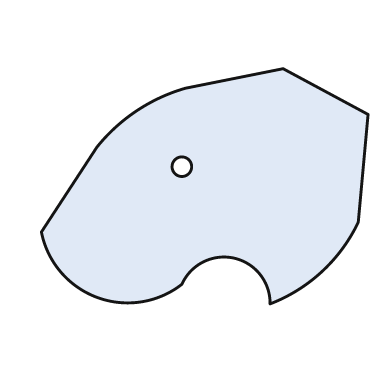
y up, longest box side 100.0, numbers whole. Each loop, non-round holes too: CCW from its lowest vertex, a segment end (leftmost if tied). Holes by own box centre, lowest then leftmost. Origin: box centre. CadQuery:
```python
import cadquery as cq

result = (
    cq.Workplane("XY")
    .moveTo(20.0, -36.0)
    .threePointArc((36.0, -26.0), (47.0, -11.0))
    .lineTo(50.0, 22.0)
    .lineTo(24.0, 36.0)
    .lineTo(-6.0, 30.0)
    .threePointArc((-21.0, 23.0), (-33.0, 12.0))
    .lineTo(-50.0, -14.0)
    .threePointArc((-33.0, -34.0), (-7.0, -30.0))
    .threePointArc((9.0, -22.0), (20.0, -36.0))
    .close()
    .moveTo(-7.0, 6.0)
    .circle(3.0)
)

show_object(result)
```